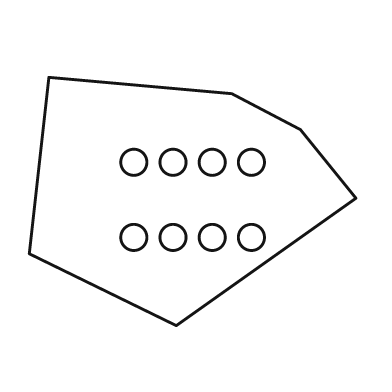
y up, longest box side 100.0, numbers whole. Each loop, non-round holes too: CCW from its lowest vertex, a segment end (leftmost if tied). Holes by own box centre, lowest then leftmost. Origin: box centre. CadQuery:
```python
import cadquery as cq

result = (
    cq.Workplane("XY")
    .moveTo(-5.0, -38.0)
    .lineTo(50.0, 1.0)
    .lineTo(33.0, 22.0)
    .lineTo(12.0, 33.0)
    .lineTo(-44.0, 38.0)
    .lineTo(-50.0, -16.0)
    .close()
    .moveTo(-18.0, -11.0)
    .circle(4.0)
    .moveTo(-6.0, -11.0)
    .circle(4.0)
    .moveTo(6.0, -11.0)
    .circle(4.0)
    .moveTo(18.0, -11.0)
    .circle(4.0)
    .moveTo(-18.0, 12.0)
    .circle(4.0)
    .moveTo(-6.0, 12.0)
    .circle(4.0)
    .moveTo(6.0, 12.0)
    .circle(4.0)
    .moveTo(18.0, 12.0)
    .circle(4.0)
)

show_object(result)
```